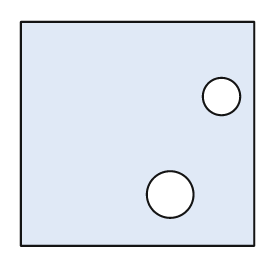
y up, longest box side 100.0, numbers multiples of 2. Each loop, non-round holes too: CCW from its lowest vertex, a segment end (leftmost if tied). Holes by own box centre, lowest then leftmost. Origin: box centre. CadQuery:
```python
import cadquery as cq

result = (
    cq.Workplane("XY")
    .moveTo(-50.0, -48.0)
    .lineTo(50.0, -48.0)
    .lineTo(50.0, 48.0)
    .lineTo(-50.0, 48.0)
    .close()
    .moveTo(14.0, -26.0)
    .circle(10.0)
    .moveTo(36.0, 16.0)
    .circle(8.0)
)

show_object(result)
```